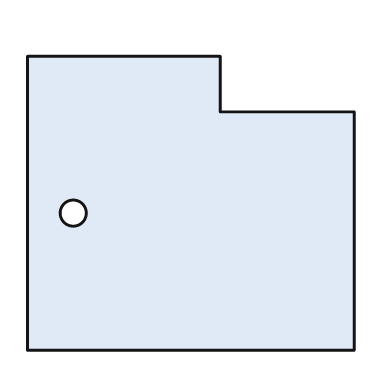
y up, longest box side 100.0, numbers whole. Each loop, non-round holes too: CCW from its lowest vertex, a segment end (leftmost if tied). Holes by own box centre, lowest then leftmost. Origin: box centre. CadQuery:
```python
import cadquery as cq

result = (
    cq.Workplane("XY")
    .moveTo(-50.0, -45.0)
    .lineTo(50.0, -45.0)
    .lineTo(50.0, 28.0)
    .lineTo(9.0, 28.0)
    .lineTo(9.0, 45.0)
    .lineTo(-50.0, 45.0)
    .close()
    .moveTo(-36.0, -3.0)
    .circle(4.0)
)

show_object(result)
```